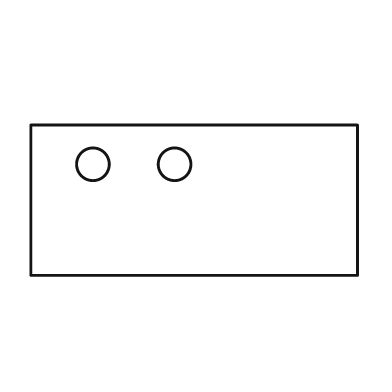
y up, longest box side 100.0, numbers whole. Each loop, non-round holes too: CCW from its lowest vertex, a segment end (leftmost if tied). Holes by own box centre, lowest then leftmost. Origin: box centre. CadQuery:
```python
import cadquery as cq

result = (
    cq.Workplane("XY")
    .moveTo(-50.0, -23.0)
    .lineTo(50.0, -23.0)
    .lineTo(50.0, 23.0)
    .lineTo(-50.0, 23.0)
    .close()
    .moveTo(-31.0, 11.0)
    .circle(5.0)
    .moveTo(-6.0, 11.0)
    .circle(5.0)
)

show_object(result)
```